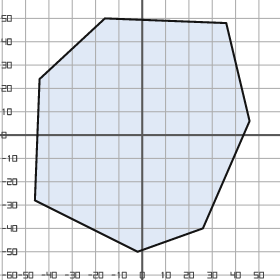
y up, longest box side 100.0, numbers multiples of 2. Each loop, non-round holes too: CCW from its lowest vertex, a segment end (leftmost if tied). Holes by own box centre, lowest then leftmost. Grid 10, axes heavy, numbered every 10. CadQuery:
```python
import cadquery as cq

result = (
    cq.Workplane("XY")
    .moveTo(-2.0, -50.0)
    .lineTo(26.0, -40.0)
    .lineTo(46.0, 6.0)
    .lineTo(36.0, 48.0)
    .lineTo(-16.0, 50.0)
    .lineTo(-44.0, 24.0)
    .lineTo(-46.0, -28.0)
    .close()
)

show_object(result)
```